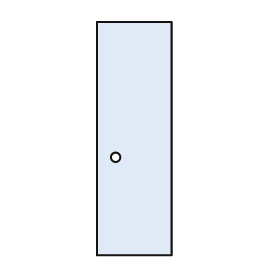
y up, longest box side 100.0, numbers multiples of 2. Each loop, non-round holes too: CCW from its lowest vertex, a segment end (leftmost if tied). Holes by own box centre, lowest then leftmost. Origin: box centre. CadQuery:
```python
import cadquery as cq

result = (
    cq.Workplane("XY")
    .moveTo(-16.0, -50.0)
    .lineTo(16.0, -50.0)
    .lineTo(16.0, 50.0)
    .lineTo(-16.0, 50.0)
    .close()
    .moveTo(-8.0, -8.0)
    .circle(2.0)
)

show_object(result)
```